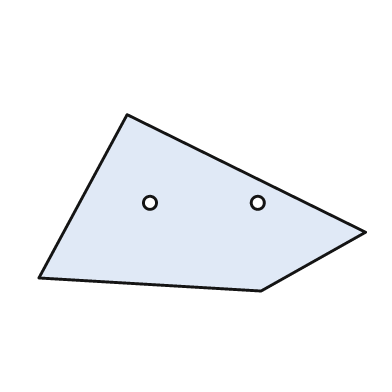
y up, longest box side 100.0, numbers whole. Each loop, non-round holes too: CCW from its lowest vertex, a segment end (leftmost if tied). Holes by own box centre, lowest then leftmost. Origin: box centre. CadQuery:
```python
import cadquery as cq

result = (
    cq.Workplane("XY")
    .moveTo(18.0, -27.0)
    .lineTo(50.0, -9.0)
    .lineTo(-23.0, 27.0)
    .lineTo(-50.0, -23.0)
    .close()
    .moveTo(-16.0, 0.0)
    .circle(2.0)
    .moveTo(17.0, 0.0)
    .circle(2.0)
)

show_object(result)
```